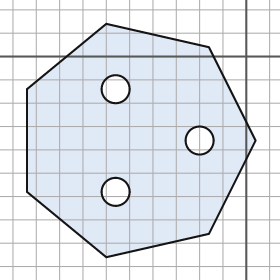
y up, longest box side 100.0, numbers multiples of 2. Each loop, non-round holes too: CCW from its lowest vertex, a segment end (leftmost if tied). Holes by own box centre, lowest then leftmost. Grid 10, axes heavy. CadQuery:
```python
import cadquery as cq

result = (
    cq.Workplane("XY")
    .moveTo(-60.0, -86.0)
    .lineTo(-16.0, -76.0)
    .lineTo(4.0, -36.0)
    .lineTo(-16.0, 4.0)
    .lineTo(-60.0, 14.0)
    .lineTo(-94.0, -14.0)
    .lineTo(-94.0, -58.0)
    .close()
    .moveTo(-56.0, -58.0)
    .circle(6.0)
    .moveTo(-20.0, -36.0)
    .circle(6.0)
    .moveTo(-56.0, -14.0)
    .circle(6.0)
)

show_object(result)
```